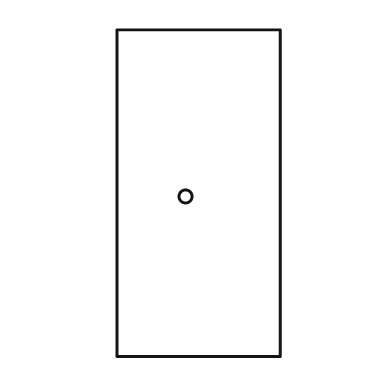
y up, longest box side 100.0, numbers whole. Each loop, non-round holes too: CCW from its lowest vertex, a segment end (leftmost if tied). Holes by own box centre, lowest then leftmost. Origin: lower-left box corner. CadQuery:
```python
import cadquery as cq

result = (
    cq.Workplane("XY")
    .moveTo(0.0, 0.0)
    .lineTo(50.0, 0.0)
    .lineTo(50.0, 100.0)
    .lineTo(0.0, 100.0)
    .close()
    .moveTo(21.0, 49.0)
    .circle(2.0)
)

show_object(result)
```